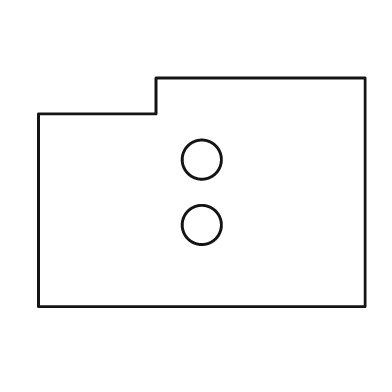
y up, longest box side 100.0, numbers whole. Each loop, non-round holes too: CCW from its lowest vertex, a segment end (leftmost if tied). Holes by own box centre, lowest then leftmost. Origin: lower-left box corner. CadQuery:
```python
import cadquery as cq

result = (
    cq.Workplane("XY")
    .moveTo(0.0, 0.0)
    .lineTo(100.0, 0.0)
    .lineTo(100.0, 70.0)
    .lineTo(36.0, 70.0)
    .lineTo(36.0, 59.0)
    .lineTo(0.0, 59.0)
    .close()
    .moveTo(50.0, 25.0)
    .circle(6.0)
    .moveTo(50.0, 45.0)
    .circle(6.0)
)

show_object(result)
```